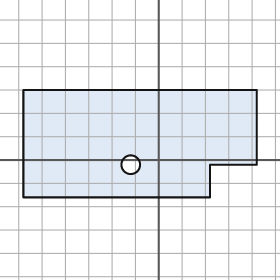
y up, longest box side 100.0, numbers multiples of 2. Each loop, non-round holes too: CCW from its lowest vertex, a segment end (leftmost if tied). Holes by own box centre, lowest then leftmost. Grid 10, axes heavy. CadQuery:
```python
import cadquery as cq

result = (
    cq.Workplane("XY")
    .moveTo(-58.0, -16.0)
    .lineTo(22.0, -16.0)
    .lineTo(22.0, -2.0)
    .lineTo(42.0, -2.0)
    .lineTo(42.0, 30.0)
    .lineTo(-58.0, 30.0)
    .close()
    .moveTo(-12.0, -2.0)
    .circle(4.0)
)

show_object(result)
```